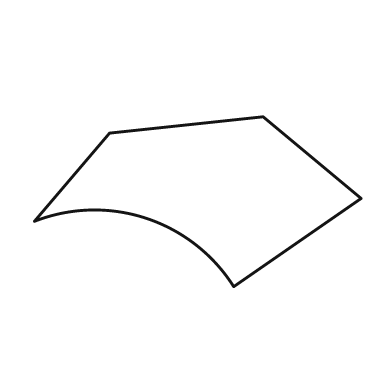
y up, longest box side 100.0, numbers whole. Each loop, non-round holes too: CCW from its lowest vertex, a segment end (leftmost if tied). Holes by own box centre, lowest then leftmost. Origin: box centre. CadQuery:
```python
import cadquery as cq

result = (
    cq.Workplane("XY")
    .moveTo(11.0, -26.0)
    .lineTo(50.0, 1.0)
    .lineTo(20.0, 26.0)
    .lineTo(-27.0, 21.0)
    .lineTo(-50.0, -6.0)
    .threePointArc((-16.0, -5.0), (11.0, -26.0))
    .close()
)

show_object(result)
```